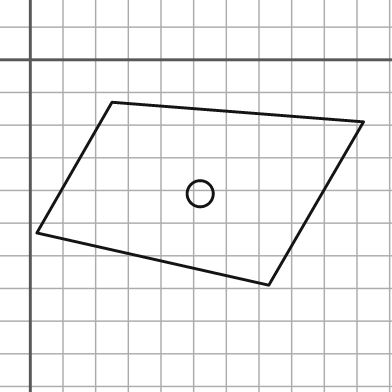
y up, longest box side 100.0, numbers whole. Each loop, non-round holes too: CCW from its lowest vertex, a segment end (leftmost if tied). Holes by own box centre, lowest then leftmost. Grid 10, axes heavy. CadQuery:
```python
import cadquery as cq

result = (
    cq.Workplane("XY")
    .moveTo(73.0, -69.0)
    .lineTo(102.0, -19.0)
    .lineTo(25.0, -13.0)
    .lineTo(2.0, -53.0)
    .close()
    .moveTo(52.0, -41.0)
    .circle(4.0)
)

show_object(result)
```